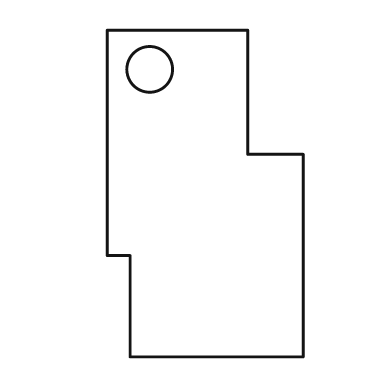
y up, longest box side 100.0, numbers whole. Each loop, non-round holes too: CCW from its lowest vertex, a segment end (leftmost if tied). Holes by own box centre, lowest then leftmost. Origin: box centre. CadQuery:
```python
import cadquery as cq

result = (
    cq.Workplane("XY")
    .moveTo(-23.0, -50.0)
    .lineTo(30.0, -50.0)
    .lineTo(30.0, 12.0)
    .lineTo(13.0, 12.0)
    .lineTo(13.0, 50.0)
    .lineTo(-30.0, 50.0)
    .lineTo(-30.0, -19.0)
    .lineTo(-23.0, -19.0)
    .close()
    .moveTo(-17.0, 38.0)
    .circle(7.0)
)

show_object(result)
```